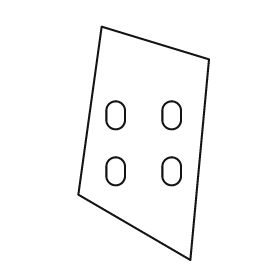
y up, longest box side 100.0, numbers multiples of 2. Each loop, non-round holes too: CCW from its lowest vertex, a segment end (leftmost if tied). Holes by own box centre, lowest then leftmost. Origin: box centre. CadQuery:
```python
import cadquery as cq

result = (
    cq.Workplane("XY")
    .moveTo(20.0, -50.0)
    .lineTo(28.0, 36.0)
    .lineTo(-18.0, 50.0)
    .lineTo(-28.0, -22.0)
    .close()
    .moveTo(-16.0, -14.0)
    .threePointArc((-12.0, -18.0), (-8.0, -14.0))
    .lineTo(-8.0, -10.0)
    .threePointArc((-12.0, -6.0), (-16.0, -10.0))
    .close()
    .moveTo(8.0, -14.0)
    .threePointArc((12.0, -18.0), (16.0, -14.0))
    .lineTo(16.0, -10.0)
    .threePointArc((12.0, -6.0), (8.0, -10.0))
    .close()
    .moveTo(-16.0, 10.0)
    .threePointArc((-12.0, 6.0), (-8.0, 10.0))
    .lineTo(-8.0, 14.0)
    .threePointArc((-12.0, 18.0), (-16.0, 14.0))
    .close()
    .moveTo(8.0, 10.0)
    .threePointArc((12.0, 6.0), (16.0, 10.0))
    .lineTo(16.0, 14.0)
    .threePointArc((12.0, 18.0), (8.0, 14.0))
    .close()
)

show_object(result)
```